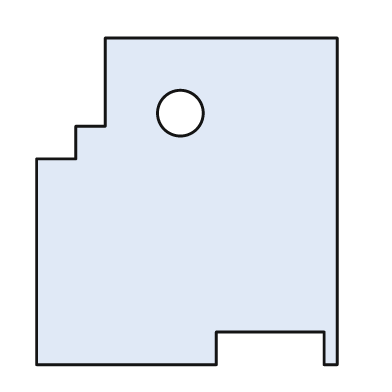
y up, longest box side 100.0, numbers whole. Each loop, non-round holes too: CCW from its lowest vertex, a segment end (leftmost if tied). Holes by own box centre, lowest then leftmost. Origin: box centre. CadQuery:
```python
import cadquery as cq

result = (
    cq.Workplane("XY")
    .moveTo(-46.0, -50.0)
    .lineTo(9.0, -50.0)
    .lineTo(9.0, -40.0)
    .lineTo(42.0, -40.0)
    .lineTo(42.0, -50.0)
    .lineTo(46.0, -50.0)
    .lineTo(46.0, 50.0)
    .lineTo(-25.0, 50.0)
    .lineTo(-25.0, 23.0)
    .lineTo(-34.0, 23.0)
    .lineTo(-34.0, 13.0)
    .lineTo(-46.0, 13.0)
    .close()
    .moveTo(-2.0, 27.0)
    .circle(7.0)
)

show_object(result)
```